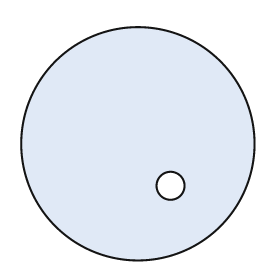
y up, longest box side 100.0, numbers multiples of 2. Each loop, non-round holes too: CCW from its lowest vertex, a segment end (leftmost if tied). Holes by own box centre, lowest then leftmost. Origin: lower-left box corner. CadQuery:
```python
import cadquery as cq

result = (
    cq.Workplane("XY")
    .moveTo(50.0, 50.0)
    .circle(50.0)
    .moveTo(64.0, 32.0)
    .circle(6.0)
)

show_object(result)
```